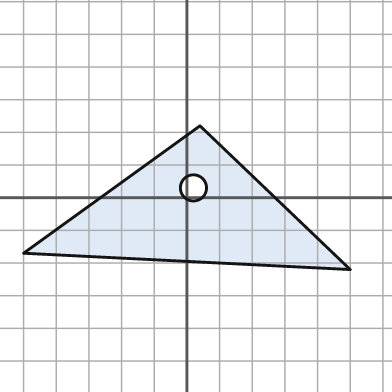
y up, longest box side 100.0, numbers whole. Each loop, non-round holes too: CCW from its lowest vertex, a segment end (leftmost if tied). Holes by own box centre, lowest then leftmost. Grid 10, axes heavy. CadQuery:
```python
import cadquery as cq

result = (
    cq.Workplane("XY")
    .moveTo(50.0, -22.0)
    .lineTo(4.0, 22.0)
    .lineTo(-50.0, -17.0)
    .close()
    .moveTo(2.0, 3.0)
    .circle(4.0)
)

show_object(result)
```